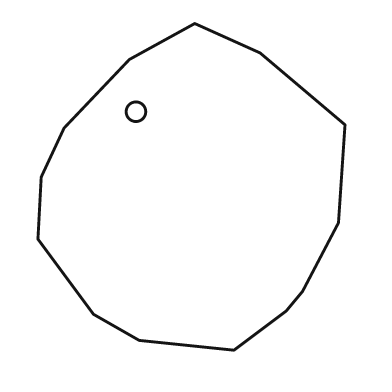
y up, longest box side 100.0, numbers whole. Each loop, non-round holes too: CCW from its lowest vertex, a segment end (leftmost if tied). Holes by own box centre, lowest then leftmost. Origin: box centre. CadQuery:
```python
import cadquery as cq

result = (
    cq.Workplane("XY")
    .moveTo(13.0, -50.0)
    .lineTo(29.0, -38.0)
    .lineTo(34.0, -32.0)
    .lineTo(45.0, -11.0)
    .lineTo(47.0, 19.0)
    .lineTo(21.0, 41.0)
    .lineTo(1.0, 50.0)
    .lineTo(-19.0, 39.0)
    .lineTo(-39.0, 18.0)
    .lineTo(-46.0, 3.0)
    .lineTo(-47.0, -16.0)
    .lineTo(-30.0, -39.0)
    .lineTo(-16.0, -47.0)
    .close()
    .moveTo(-17.0, 23.0)
    .circle(3.0)
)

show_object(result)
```